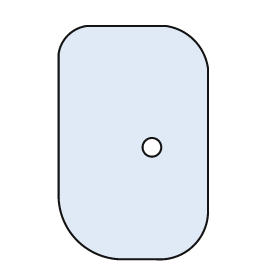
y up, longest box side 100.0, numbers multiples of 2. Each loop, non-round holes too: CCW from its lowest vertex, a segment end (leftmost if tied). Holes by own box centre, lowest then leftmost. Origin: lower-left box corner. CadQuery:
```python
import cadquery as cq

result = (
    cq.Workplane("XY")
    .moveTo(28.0, 0.0)
    .lineTo(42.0, 0.0)
    .threePointArc((58.0, 6.0), (64.0, 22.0))
    .lineTo(64.0, 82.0)
    .threePointArc((58.0, 94.0), (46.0, 100.0))
    .lineTo(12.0, 100.0)
    .threePointArc((4.0, 96.0), (0.0, 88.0))
    .lineTo(0.0, 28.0)
    .threePointArc((8.0, 8.0), (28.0, 0.0))
    .close()
    .moveTo(40.0, 48.0)
    .circle(4.0)
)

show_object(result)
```